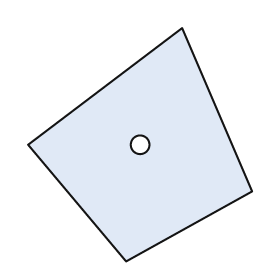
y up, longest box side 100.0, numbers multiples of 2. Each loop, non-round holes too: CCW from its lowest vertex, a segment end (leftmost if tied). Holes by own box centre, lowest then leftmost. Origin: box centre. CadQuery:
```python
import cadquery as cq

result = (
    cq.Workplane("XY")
    .moveTo(-6.0, -50.0)
    .lineTo(48.0, -20.0)
    .lineTo(18.0, 50.0)
    .lineTo(-48.0, 0.0)
    .close()
    .moveTo(0.0, 0.0)
    .circle(4.0)
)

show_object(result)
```